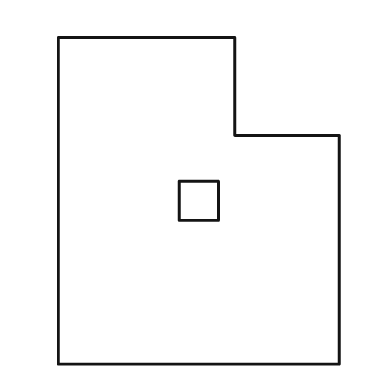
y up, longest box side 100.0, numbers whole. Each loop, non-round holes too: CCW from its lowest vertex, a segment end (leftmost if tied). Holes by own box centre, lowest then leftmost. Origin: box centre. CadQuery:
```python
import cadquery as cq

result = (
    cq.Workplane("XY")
    .moveTo(-43.0, -50.0)
    .lineTo(43.0, -50.0)
    .lineTo(43.0, 20.0)
    .lineTo(11.0, 20.0)
    .lineTo(11.0, 50.0)
    .lineTo(-43.0, 50.0)
    .close()
    .moveTo(-6.0, -6.0)
    .lineTo(6.0, -6.0)
    .lineTo(6.0, 6.0)
    .lineTo(-6.0, 6.0)
    .close()
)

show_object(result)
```